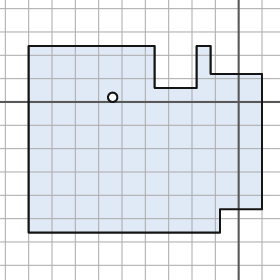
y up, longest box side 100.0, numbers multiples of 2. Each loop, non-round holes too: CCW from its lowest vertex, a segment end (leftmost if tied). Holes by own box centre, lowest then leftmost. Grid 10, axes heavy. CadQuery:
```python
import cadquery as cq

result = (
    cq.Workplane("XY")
    .moveTo(-90.0, -56.0)
    .lineTo(-8.0, -56.0)
    .lineTo(-8.0, -46.0)
    .lineTo(10.0, -46.0)
    .lineTo(10.0, 12.0)
    .lineTo(-12.0, 12.0)
    .lineTo(-12.0, 24.0)
    .lineTo(-18.0, 24.0)
    .lineTo(-18.0, 6.0)
    .lineTo(-36.0, 6.0)
    .lineTo(-36.0, 24.0)
    .lineTo(-90.0, 24.0)
    .close()
    .moveTo(-54.0, 2.0)
    .circle(2.0)
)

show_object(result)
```